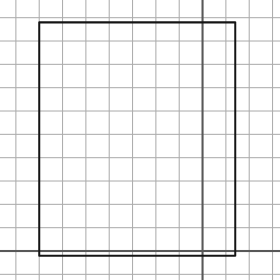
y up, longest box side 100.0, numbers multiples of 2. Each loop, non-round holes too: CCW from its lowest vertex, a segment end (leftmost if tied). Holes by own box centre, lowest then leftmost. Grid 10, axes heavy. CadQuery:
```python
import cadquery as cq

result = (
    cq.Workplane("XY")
    .moveTo(-70.0, -2.0)
    .lineTo(14.0, -2.0)
    .lineTo(14.0, 98.0)
    .lineTo(-70.0, 98.0)
    .close()
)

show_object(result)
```